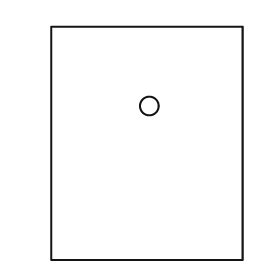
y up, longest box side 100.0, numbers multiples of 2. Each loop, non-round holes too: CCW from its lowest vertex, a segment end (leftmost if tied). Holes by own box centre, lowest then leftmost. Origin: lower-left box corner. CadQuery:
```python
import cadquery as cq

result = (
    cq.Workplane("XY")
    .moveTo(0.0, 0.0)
    .lineTo(82.0, 0.0)
    .lineTo(82.0, 100.0)
    .lineTo(0.0, 100.0)
    .close()
    .moveTo(42.0, 66.0)
    .circle(4.0)
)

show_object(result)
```